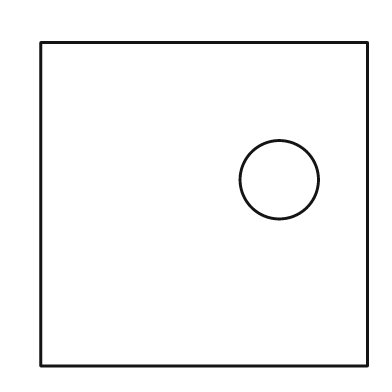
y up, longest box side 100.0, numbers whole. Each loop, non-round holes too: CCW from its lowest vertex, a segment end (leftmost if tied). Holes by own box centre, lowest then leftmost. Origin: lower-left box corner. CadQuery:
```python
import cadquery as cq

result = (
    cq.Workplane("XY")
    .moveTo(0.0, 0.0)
    .lineTo(100.0, 0.0)
    .lineTo(100.0, 99.0)
    .lineTo(0.0, 99.0)
    .close()
    .moveTo(73.0, 57.0)
    .circle(12.0)
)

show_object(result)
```